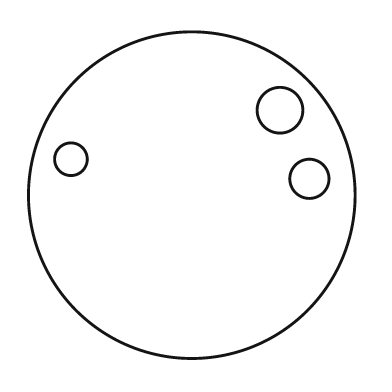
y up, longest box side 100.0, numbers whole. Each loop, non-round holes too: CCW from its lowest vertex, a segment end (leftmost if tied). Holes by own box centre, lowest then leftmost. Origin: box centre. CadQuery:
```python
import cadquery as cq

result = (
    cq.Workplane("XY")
    .moveTo(0.0, 0.0)
    .circle(50.0)
    .moveTo(36.0, 5.0)
    .circle(6.0)
    .moveTo(-37.0, 11.0)
    .circle(5.0)
    .moveTo(27.0, 26.0)
    .circle(7.0)
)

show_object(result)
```